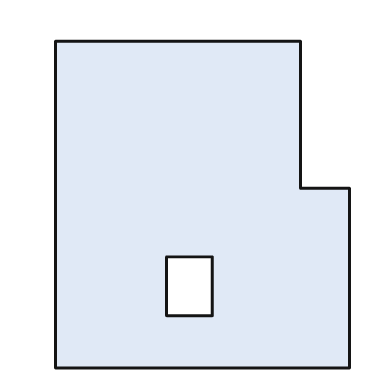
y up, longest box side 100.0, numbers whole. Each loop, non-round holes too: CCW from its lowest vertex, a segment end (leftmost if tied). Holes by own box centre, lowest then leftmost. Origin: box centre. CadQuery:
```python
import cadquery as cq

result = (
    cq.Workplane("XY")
    .moveTo(-45.0, -50.0)
    .lineTo(45.0, -50.0)
    .lineTo(45.0, 5.0)
    .lineTo(30.0, 5.0)
    .lineTo(30.0, 50.0)
    .lineTo(-45.0, 50.0)
    .close()
    .moveTo(-11.0, -34.0)
    .lineTo(3.0, -34.0)
    .lineTo(3.0, -16.0)
    .lineTo(-11.0, -16.0)
    .close()
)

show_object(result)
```